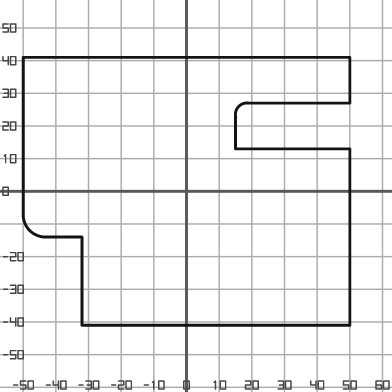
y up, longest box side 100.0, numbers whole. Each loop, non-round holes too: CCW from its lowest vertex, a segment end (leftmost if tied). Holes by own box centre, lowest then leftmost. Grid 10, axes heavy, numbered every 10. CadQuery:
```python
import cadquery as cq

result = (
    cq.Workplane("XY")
    .moveTo(-32.0, -41.0)
    .lineTo(50.0, -41.0)
    .lineTo(50.0, 13.0)
    .lineTo(15.0, 13.0)
    .lineTo(15.0, 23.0)
    .threePointArc((16.0, 26.0), (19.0, 27.0))
    .lineTo(50.0, 27.0)
    .lineTo(50.0, 41.0)
    .lineTo(-50.0, 41.0)
    .lineTo(-50.0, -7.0)
    .threePointArc((-48.0, -12.0), (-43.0, -14.0))
    .lineTo(-32.0, -14.0)
    .close()
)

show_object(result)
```